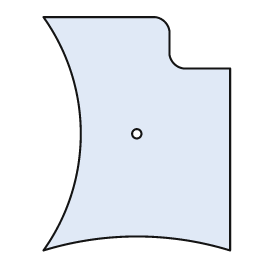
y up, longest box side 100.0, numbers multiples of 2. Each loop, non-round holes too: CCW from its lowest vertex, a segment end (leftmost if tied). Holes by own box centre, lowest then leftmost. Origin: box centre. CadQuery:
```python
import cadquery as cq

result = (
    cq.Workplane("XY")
    .moveTo(-40.0, -50.0)
    .threePointArc((0.0, -44.0), (40.0, -50.0))
    .lineTo(40.0, 28.0)
    .lineTo(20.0, 28.0)
    .threePointArc((16.0, 30.0), (14.0, 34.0))
    .lineTo(14.0, 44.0)
    .threePointArc((12.0, 48.0), (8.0, 50.0))
    .lineTo(-40.0, 50.0)
    .threePointArc((-24.0, 0.0), (-40.0, -50.0))
    .close()
    .moveTo(0.0, 0.0)
    .circle(2.0)
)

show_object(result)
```